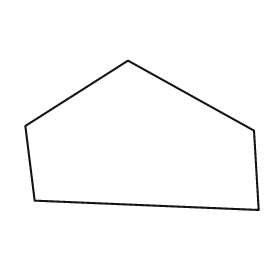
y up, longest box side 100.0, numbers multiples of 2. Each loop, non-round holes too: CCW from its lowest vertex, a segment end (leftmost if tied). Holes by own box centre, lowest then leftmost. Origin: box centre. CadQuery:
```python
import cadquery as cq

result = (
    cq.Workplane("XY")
    .moveTo(50.0, -32.0)
    .lineTo(48.0, 2.0)
    .lineTo(-6.0, 32.0)
    .lineTo(-50.0, 4.0)
    .lineTo(-46.0, -28.0)
    .close()
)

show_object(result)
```